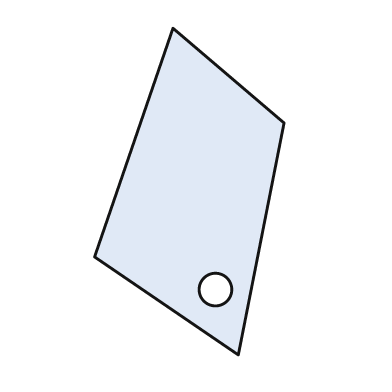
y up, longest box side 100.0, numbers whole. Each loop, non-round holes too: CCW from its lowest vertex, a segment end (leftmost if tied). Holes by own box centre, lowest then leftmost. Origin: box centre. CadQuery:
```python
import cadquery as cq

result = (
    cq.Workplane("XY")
    .moveTo(15.0, -50.0)
    .lineTo(29.0, 21.0)
    .lineTo(-5.0, 50.0)
    .lineTo(-29.0, -20.0)
    .close()
    .moveTo(8.0, -30.0)
    .circle(5.0)
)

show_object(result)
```